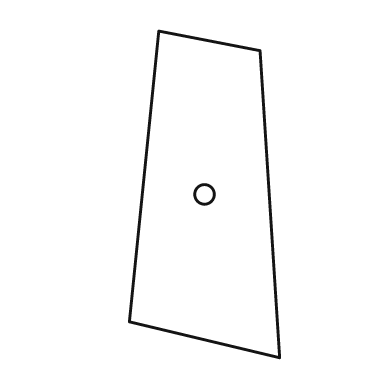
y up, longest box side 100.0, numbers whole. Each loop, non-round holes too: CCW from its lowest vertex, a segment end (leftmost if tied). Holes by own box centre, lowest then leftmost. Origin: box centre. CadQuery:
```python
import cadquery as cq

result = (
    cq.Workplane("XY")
    .moveTo(23.0, -50.0)
    .lineTo(17.0, 44.0)
    .lineTo(-14.0, 50.0)
    .lineTo(-23.0, -39.0)
    .close()
    .moveTo(0.0, 0.0)
    .circle(3.0)
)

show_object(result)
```